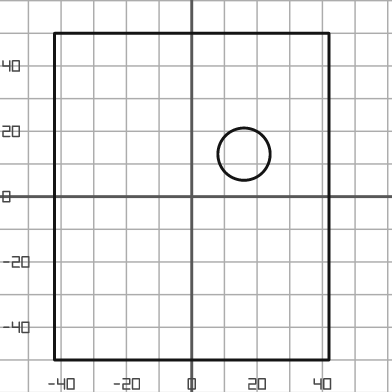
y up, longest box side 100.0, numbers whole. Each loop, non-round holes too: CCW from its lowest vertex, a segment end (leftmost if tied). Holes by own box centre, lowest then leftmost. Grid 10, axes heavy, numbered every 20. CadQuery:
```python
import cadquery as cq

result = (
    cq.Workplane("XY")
    .moveTo(-42.0, -50.0)
    .lineTo(42.0, -50.0)
    .lineTo(42.0, 50.0)
    .lineTo(-42.0, 50.0)
    .close()
    .moveTo(16.0, 13.0)
    .circle(8.0)
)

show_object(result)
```